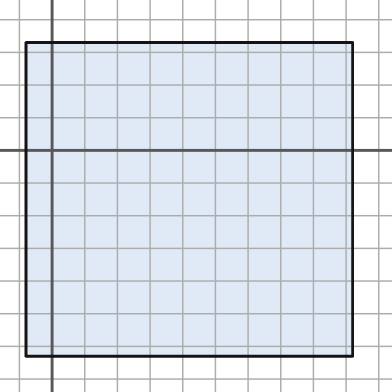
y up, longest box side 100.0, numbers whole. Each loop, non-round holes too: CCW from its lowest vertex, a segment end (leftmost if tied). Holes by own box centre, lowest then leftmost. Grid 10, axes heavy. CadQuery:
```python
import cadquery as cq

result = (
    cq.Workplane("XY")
    .moveTo(-8.0, -63.0)
    .lineTo(92.0, -63.0)
    .lineTo(92.0, 33.0)
    .lineTo(-8.0, 33.0)
    .close()
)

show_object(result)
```